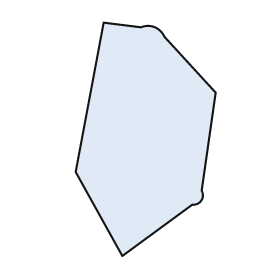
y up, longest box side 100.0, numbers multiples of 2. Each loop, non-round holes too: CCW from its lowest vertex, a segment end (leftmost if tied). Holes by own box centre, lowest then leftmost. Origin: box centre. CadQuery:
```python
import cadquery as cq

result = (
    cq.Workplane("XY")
    .moveTo(-10.0, -50.0)
    .lineTo(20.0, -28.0)
    .threePointArc((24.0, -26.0), (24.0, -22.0))
    .lineTo(30.0, 20.0)
    .lineTo(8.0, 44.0)
    .threePointArc((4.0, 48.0), (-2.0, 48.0))
    .lineTo(-18.0, 50.0)
    .lineTo(-30.0, -14.0)
    .close()
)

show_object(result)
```